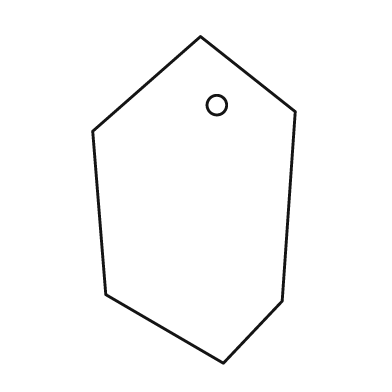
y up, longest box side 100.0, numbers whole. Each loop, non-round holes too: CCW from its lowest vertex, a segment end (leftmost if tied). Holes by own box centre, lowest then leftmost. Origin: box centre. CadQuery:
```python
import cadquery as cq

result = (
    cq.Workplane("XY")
    .moveTo(9.0, -50.0)
    .lineTo(27.0, -31.0)
    .lineTo(31.0, 27.0)
    .lineTo(2.0, 50.0)
    .lineTo(-31.0, 21.0)
    .lineTo(-27.0, -29.0)
    .close()
    .moveTo(7.0, 29.0)
    .circle(3.0)
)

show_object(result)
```